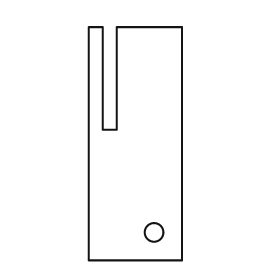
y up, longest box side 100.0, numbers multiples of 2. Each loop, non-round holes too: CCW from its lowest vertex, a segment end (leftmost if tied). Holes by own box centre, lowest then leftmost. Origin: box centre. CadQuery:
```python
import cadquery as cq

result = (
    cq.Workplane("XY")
    .moveTo(-20.0, -50.0)
    .lineTo(20.0, -50.0)
    .lineTo(20.0, 50.0)
    .lineTo(-8.0, 50.0)
    .lineTo(-8.0, 6.0)
    .lineTo(-14.0, 6.0)
    .lineTo(-14.0, 50.0)
    .lineTo(-20.0, 50.0)
    .close()
    .moveTo(8.0, -38.0)
    .circle(4.0)
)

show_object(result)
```